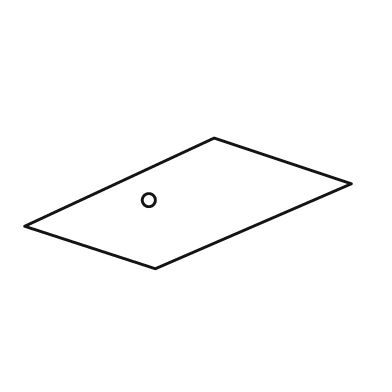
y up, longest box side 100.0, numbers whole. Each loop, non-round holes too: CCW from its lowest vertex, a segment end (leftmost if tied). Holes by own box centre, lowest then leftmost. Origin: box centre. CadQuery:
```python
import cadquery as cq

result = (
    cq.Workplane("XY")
    .moveTo(-10.0, -20.0)
    .lineTo(50.0, 6.0)
    .lineTo(8.0, 20.0)
    .lineTo(-50.0, -7.0)
    .close()
    .moveTo(-12.0, 1.0)
    .circle(2.0)
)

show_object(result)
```